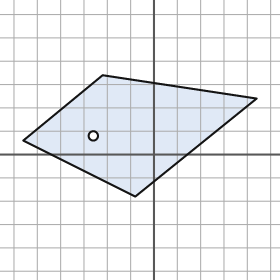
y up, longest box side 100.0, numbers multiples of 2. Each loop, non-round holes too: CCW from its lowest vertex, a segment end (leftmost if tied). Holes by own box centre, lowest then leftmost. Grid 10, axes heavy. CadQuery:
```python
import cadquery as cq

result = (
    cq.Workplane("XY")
    .moveTo(-8.0, -18.0)
    .lineTo(44.0, 24.0)
    .lineTo(-22.0, 34.0)
    .lineTo(-56.0, 6.0)
    .close()
    .moveTo(-26.0, 8.0)
    .circle(2.0)
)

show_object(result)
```